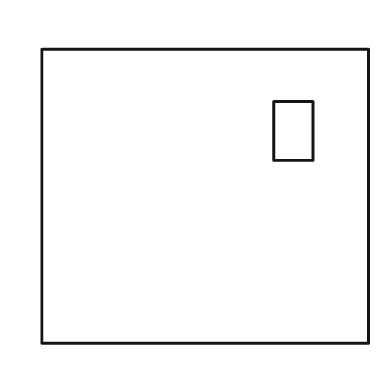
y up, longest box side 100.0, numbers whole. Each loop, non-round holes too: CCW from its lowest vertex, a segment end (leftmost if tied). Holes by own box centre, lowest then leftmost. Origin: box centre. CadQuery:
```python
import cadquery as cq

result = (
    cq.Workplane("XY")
    .moveTo(-50.0, -45.0)
    .lineTo(50.0, -45.0)
    .lineTo(50.0, 45.0)
    .lineTo(-50.0, 45.0)
    .close()
    .moveTo(21.0, 11.0)
    .lineTo(33.0, 11.0)
    .lineTo(33.0, 29.0)
    .lineTo(21.0, 29.0)
    .close()
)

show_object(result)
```